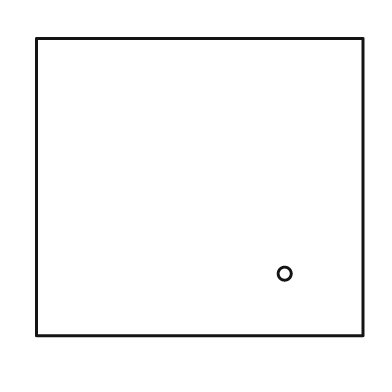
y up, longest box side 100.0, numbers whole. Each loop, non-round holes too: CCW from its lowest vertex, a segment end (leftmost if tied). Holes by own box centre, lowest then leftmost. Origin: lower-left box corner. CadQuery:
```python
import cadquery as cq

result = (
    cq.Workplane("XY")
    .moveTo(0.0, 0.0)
    .lineTo(100.0, 0.0)
    .lineTo(100.0, 91.0)
    .lineTo(0.0, 91.0)
    .close()
    .moveTo(76.0, 19.0)
    .circle(2.0)
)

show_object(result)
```